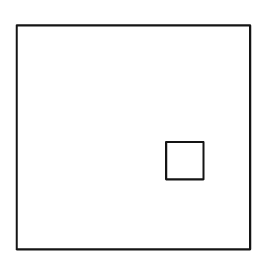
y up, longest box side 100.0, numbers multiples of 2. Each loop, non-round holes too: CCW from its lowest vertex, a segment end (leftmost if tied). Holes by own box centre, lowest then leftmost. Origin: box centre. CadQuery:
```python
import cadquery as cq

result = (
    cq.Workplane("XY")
    .moveTo(-50.0, -48.0)
    .lineTo(50.0, -48.0)
    .lineTo(50.0, 48.0)
    .lineTo(-50.0, 48.0)
    .close()
    .moveTo(14.0, -18.0)
    .lineTo(30.0, -18.0)
    .lineTo(30.0, -2.0)
    .lineTo(14.0, -2.0)
    .close()
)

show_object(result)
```